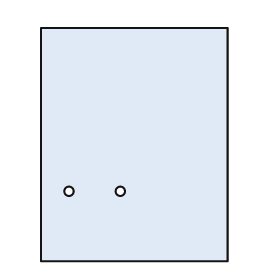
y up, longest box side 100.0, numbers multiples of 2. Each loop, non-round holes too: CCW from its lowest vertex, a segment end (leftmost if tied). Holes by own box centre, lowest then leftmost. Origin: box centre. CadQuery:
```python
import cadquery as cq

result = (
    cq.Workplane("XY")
    .moveTo(-40.0, -50.0)
    .lineTo(40.0, -50.0)
    .lineTo(40.0, 50.0)
    .lineTo(-40.0, 50.0)
    .close()
    .moveTo(-28.0, -20.0)
    .circle(2.0)
    .moveTo(-6.0, -20.0)
    .circle(2.0)
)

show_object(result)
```